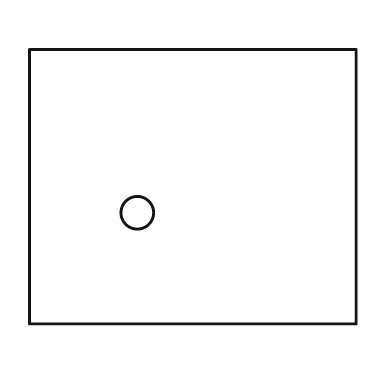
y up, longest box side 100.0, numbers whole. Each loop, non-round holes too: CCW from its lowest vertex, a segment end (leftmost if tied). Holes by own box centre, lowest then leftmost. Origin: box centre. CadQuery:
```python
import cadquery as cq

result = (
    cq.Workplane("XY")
    .moveTo(-50.0, -42.0)
    .lineTo(50.0, -42.0)
    .lineTo(50.0, 42.0)
    .lineTo(-50.0, 42.0)
    .close()
    .moveTo(-17.0, -8.0)
    .circle(5.0)
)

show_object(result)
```